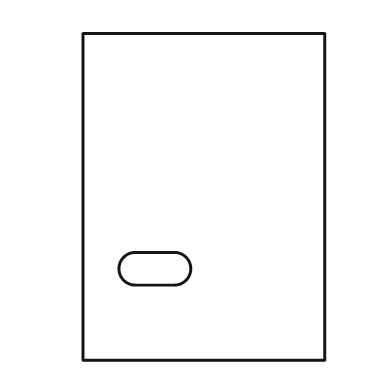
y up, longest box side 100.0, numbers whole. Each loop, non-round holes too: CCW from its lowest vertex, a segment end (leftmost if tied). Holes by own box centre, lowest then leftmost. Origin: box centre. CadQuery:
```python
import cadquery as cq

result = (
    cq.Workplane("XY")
    .moveTo(-37.0, -50.0)
    .lineTo(37.0, -50.0)
    .lineTo(37.0, 50.0)
    .lineTo(-37.0, 50.0)
    .close()
    .moveTo(-21.0, -27.0)
    .lineTo(-9.0, -27.0)
    .threePointArc((-4.0, -22.0), (-9.0, -17.0))
    .lineTo(-21.0, -17.0)
    .threePointArc((-26.0, -22.0), (-21.0, -27.0))
    .close()
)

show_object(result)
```